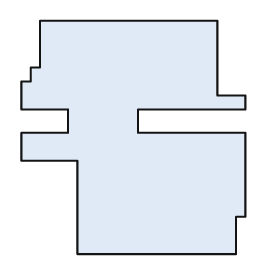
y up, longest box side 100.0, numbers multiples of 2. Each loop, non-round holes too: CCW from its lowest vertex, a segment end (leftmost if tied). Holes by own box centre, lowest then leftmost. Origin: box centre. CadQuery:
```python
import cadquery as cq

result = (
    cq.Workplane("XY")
    .moveTo(-24.0, -50.0)
    .lineTo(44.0, -50.0)
    .lineTo(44.0, -34.0)
    .lineTo(48.0, -34.0)
    .lineTo(48.0, 2.0)
    .lineTo(2.0, 2.0)
    .lineTo(2.0, 12.0)
    .lineTo(48.0, 12.0)
    .lineTo(48.0, 18.0)
    .lineTo(36.0, 18.0)
    .lineTo(36.0, 50.0)
    .lineTo(-40.0, 50.0)
    .lineTo(-40.0, 30.0)
    .lineTo(-44.0, 30.0)
    .lineTo(-44.0, 24.0)
    .lineTo(-48.0, 24.0)
    .lineTo(-48.0, 12.0)
    .lineTo(-28.0, 12.0)
    .lineTo(-28.0, 2.0)
    .lineTo(-48.0, 2.0)
    .lineTo(-48.0, -10.0)
    .lineTo(-24.0, -10.0)
    .close()
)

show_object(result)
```